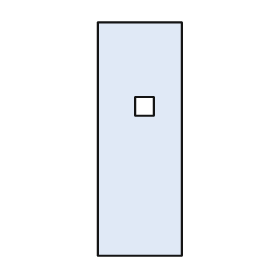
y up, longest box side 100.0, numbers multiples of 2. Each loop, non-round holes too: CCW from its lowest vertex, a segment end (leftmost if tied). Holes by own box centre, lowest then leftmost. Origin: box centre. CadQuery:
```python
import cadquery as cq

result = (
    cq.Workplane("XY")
    .moveTo(-18.0, -50.0)
    .lineTo(18.0, -50.0)
    .lineTo(18.0, 50.0)
    .lineTo(-18.0, 50.0)
    .close()
    .moveTo(-2.0, 10.0)
    .lineTo(6.0, 10.0)
    .lineTo(6.0, 18.0)
    .lineTo(-2.0, 18.0)
    .close()
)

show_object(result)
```